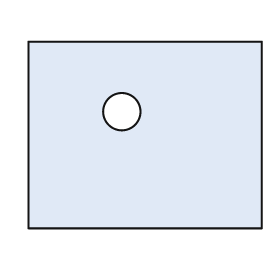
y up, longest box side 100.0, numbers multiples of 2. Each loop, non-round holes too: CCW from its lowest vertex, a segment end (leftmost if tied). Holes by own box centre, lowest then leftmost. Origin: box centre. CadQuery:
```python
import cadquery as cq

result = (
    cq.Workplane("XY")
    .moveTo(-50.0, -40.0)
    .lineTo(50.0, -40.0)
    .lineTo(50.0, 40.0)
    .lineTo(-50.0, 40.0)
    .close()
    .moveTo(-10.0, 10.0)
    .circle(8.0)
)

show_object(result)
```